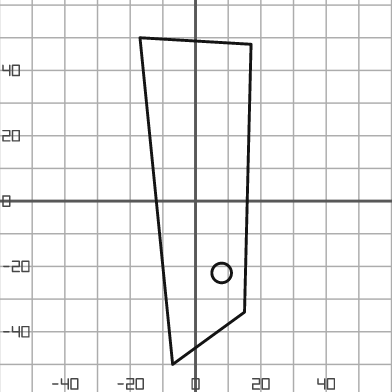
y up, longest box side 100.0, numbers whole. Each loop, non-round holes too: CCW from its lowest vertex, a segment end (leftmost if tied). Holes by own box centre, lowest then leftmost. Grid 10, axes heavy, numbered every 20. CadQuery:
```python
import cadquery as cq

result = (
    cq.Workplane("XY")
    .moveTo(-7.0, -50.0)
    .lineTo(15.0, -34.0)
    .lineTo(17.0, 48.0)
    .lineTo(-17.0, 50.0)
    .close()
    .moveTo(8.0, -22.0)
    .circle(3.0)
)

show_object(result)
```